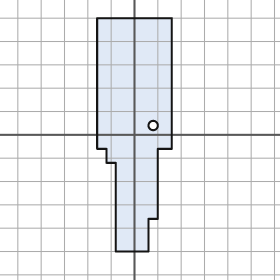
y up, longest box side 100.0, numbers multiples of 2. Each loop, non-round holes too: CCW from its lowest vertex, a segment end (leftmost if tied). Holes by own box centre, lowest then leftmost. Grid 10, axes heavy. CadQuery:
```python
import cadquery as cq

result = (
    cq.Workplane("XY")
    .moveTo(-8.0, -50.0)
    .lineTo(6.0, -50.0)
    .lineTo(6.0, -36.0)
    .lineTo(10.0, -36.0)
    .lineTo(10.0, -6.0)
    .lineTo(16.0, -6.0)
    .lineTo(16.0, 50.0)
    .lineTo(-16.0, 50.0)
    .lineTo(-16.0, -6.0)
    .lineTo(-12.0, -6.0)
    .lineTo(-12.0, -12.0)
    .lineTo(-8.0, -12.0)
    .close()
    .moveTo(8.0, 4.0)
    .circle(2.0)
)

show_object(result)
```